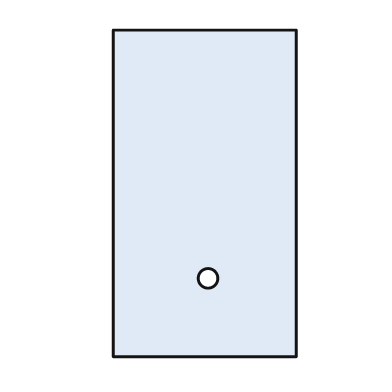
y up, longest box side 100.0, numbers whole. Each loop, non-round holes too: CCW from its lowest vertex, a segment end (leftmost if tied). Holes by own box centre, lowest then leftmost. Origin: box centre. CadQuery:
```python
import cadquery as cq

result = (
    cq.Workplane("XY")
    .moveTo(-28.0, -50.0)
    .lineTo(28.0, -50.0)
    .lineTo(28.0, 50.0)
    .lineTo(-28.0, 50.0)
    .close()
    .moveTo(1.0, -26.0)
    .circle(3.0)
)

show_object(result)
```